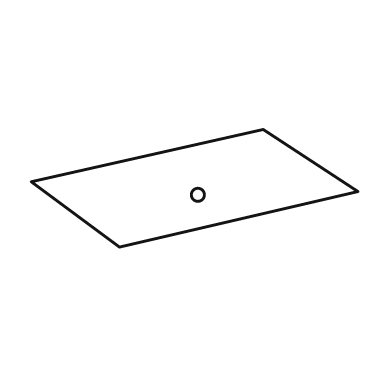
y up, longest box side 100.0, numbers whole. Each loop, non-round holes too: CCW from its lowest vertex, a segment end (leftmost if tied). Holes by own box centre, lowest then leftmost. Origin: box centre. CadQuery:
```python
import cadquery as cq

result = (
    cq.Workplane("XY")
    .moveTo(-23.0, -18.0)
    .lineTo(50.0, -1.0)
    .lineTo(21.0, 18.0)
    .lineTo(-50.0, 2.0)
    .close()
    .moveTo(1.0, -2.0)
    .circle(2.0)
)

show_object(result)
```